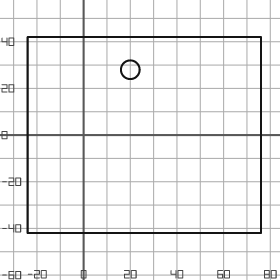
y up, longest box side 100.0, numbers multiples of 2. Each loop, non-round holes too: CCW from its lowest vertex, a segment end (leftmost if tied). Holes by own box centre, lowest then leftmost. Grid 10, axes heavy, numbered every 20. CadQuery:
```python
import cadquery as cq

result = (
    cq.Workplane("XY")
    .moveTo(-24.0, -42.0)
    .lineTo(76.0, -42.0)
    .lineTo(76.0, 42.0)
    .lineTo(-24.0, 42.0)
    .close()
    .moveTo(20.0, 28.0)
    .circle(4.0)
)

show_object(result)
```